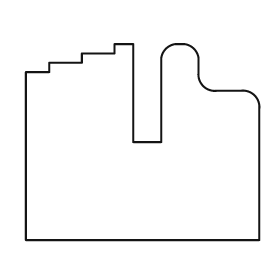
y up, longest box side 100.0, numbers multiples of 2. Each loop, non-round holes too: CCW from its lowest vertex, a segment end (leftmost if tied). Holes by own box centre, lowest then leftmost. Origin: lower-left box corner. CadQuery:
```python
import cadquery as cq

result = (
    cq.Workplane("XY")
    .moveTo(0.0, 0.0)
    .lineTo(100.0, 0.0)
    .lineTo(100.0, 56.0)
    .threePointArc((98.0, 62.0), (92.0, 64.0))
    .lineTo(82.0, 64.0)
    .threePointArc((76.0, 66.0), (74.0, 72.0))
    .lineTo(74.0, 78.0)
    .threePointArc((72.0, 82.0), (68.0, 84.0))
    .lineTo(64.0, 84.0)
    .threePointArc((60.0, 82.0), (58.0, 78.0))
    .lineTo(58.0, 42.0)
    .lineTo(46.0, 42.0)
    .lineTo(46.0, 84.0)
    .lineTo(38.0, 84.0)
    .lineTo(38.0, 80.0)
    .lineTo(24.0, 80.0)
    .lineTo(24.0, 76.0)
    .lineTo(10.0, 76.0)
    .lineTo(10.0, 72.0)
    .lineTo(0.0, 72.0)
    .close()
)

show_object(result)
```